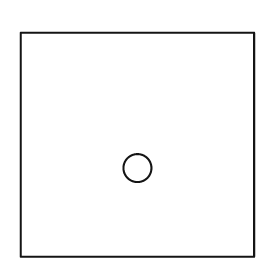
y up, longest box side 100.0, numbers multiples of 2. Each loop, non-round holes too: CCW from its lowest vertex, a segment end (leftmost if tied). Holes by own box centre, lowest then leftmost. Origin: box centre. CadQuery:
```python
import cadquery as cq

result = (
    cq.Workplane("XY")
    .moveTo(-50.0, -48.0)
    .lineTo(50.0, -48.0)
    .lineTo(50.0, 48.0)
    .lineTo(-50.0, 48.0)
    .close()
    .moveTo(0.0, -10.0)
    .circle(6.0)
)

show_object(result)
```